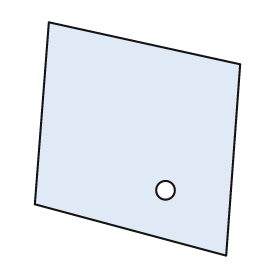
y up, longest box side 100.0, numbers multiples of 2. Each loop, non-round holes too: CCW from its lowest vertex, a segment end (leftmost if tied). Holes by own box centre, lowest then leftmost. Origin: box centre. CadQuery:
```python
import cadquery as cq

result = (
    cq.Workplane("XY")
    .moveTo(38.0, -50.0)
    .lineTo(44.0, 32.0)
    .lineTo(-38.0, 50.0)
    .lineTo(-44.0, -28.0)
    .close()
    .moveTo(12.0, -22.0)
    .circle(4.0)
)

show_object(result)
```